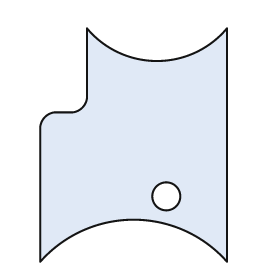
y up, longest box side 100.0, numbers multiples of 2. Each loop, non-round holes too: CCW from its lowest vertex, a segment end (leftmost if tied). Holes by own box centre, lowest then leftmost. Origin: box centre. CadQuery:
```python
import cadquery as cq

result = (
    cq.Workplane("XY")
    .moveTo(-40.0, -50.0)
    .threePointArc((0.0, -32.0), (40.0, -50.0))
    .lineTo(40.0, 50.0)
    .threePointArc((10.0, 36.0), (-20.0, 50.0))
    .lineTo(-20.0, 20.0)
    .threePointArc((-22.0, 16.0), (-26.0, 14.0))
    .lineTo(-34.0, 14.0)
    .threePointArc((-38.0, 12.0), (-40.0, 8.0))
    .close()
    .moveTo(14.0, -22.0)
    .circle(6.0)
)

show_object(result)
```